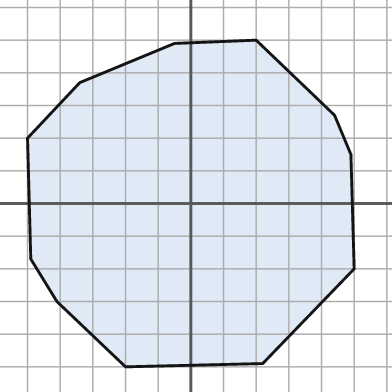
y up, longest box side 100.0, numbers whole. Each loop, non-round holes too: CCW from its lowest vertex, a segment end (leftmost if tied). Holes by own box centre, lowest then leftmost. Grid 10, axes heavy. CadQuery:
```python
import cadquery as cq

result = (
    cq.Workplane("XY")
    .moveTo(-20.0, -50.0)
    .lineTo(22.0, -49.0)
    .lineTo(50.0, -20.0)
    .lineTo(49.0, 15.0)
    .lineTo(44.0, 27.0)
    .lineTo(20.0, 50.0)
    .lineTo(-5.0, 49.0)
    .lineTo(-34.0, 37.0)
    .lineTo(-50.0, 20.0)
    .lineTo(-49.0, -17.0)
    .lineTo(-41.0, -30.0)
    .close()
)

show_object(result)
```